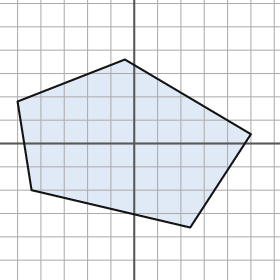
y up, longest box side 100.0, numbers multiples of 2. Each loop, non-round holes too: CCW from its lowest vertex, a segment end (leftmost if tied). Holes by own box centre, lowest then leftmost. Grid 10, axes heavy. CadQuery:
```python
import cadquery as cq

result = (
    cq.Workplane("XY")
    .moveTo(24.0, -36.0)
    .lineTo(50.0, 4.0)
    .lineTo(-4.0, 36.0)
    .lineTo(-50.0, 18.0)
    .lineTo(-44.0, -20.0)
    .close()
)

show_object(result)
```